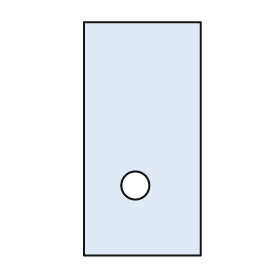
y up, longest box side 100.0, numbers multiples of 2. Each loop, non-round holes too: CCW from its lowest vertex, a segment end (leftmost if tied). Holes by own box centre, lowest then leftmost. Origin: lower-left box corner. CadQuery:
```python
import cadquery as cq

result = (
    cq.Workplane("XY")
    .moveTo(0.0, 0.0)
    .lineTo(50.0, 0.0)
    .lineTo(50.0, 100.0)
    .lineTo(0.0, 100.0)
    .close()
    .moveTo(22.0, 30.0)
    .circle(6.0)
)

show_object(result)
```